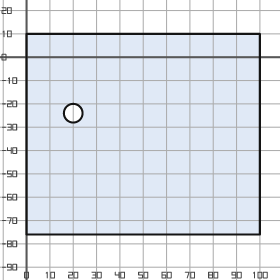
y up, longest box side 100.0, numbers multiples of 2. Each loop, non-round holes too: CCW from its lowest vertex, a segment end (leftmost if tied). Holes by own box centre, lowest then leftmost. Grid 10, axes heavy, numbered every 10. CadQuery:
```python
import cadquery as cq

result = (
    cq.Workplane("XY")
    .moveTo(0.0, -76.0)
    .lineTo(100.0, -76.0)
    .lineTo(100.0, 10.0)
    .lineTo(0.0, 10.0)
    .close()
    .moveTo(20.0, -24.0)
    .circle(4.0)
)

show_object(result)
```